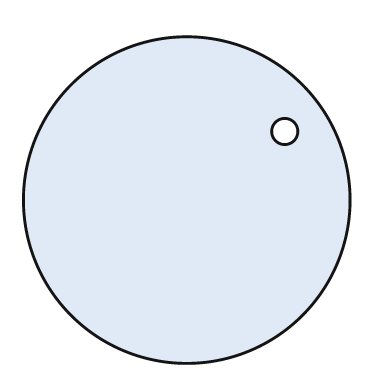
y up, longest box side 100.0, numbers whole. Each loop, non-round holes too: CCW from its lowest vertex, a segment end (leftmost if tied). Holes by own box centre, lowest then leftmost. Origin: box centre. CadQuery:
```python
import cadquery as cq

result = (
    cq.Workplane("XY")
    .moveTo(0.0, 0.0)
    .circle(50.0)
    .moveTo(30.0, 21.0)
    .circle(4.0)
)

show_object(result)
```